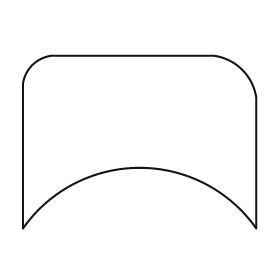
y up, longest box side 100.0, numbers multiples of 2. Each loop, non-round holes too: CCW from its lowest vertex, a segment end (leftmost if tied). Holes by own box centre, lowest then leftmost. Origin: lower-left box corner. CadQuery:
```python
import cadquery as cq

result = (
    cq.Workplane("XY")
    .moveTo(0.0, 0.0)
    .threePointArc((50.0, 26.0), (100.0, 0.0))
    .lineTo(100.0, 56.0)
    .threePointArc((94.0, 68.0), (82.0, 74.0))
    .lineTo(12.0, 74.0)
    .threePointArc((4.0, 70.0), (0.0, 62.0))
    .close()
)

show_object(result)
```